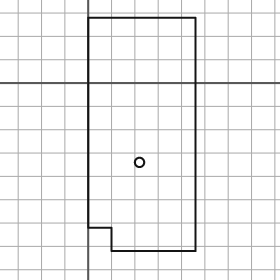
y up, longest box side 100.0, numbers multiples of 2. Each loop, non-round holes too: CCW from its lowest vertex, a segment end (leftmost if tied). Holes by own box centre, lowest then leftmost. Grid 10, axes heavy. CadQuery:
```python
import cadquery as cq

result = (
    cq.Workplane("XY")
    .moveTo(10.0, -72.0)
    .lineTo(46.0, -72.0)
    .lineTo(46.0, 28.0)
    .lineTo(0.0, 28.0)
    .lineTo(0.0, -62.0)
    .lineTo(10.0, -62.0)
    .close()
    .moveTo(22.0, -34.0)
    .circle(2.0)
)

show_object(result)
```